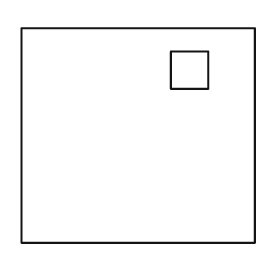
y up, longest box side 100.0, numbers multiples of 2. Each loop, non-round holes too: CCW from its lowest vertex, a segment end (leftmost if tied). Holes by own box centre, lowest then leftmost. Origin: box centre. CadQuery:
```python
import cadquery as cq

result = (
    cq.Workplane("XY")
    .moveTo(-50.0, -46.0)
    .lineTo(50.0, -46.0)
    .lineTo(50.0, 46.0)
    .lineTo(-50.0, 46.0)
    .close()
    .moveTo(14.0, 20.0)
    .lineTo(30.0, 20.0)
    .lineTo(30.0, 36.0)
    .lineTo(14.0, 36.0)
    .close()
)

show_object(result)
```